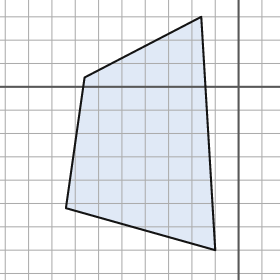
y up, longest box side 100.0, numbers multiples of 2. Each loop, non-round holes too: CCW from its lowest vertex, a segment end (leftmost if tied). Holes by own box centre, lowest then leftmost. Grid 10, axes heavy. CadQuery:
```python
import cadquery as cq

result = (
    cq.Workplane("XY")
    .moveTo(-10.0, -70.0)
    .lineTo(-16.0, 30.0)
    .lineTo(-66.0, 4.0)
    .lineTo(-74.0, -52.0)
    .close()
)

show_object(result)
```